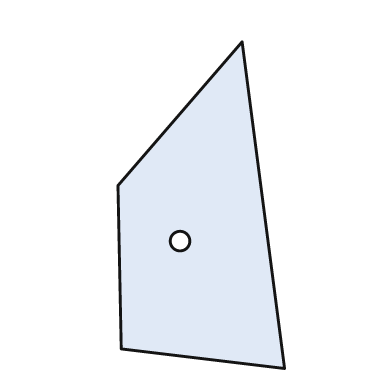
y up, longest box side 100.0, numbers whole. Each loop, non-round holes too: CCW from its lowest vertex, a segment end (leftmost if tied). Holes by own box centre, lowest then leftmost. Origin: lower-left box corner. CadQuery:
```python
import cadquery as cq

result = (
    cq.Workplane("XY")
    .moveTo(51.0, 0.0)
    .lineTo(38.0, 100.0)
    .lineTo(0.0, 56.0)
    .lineTo(1.0, 6.0)
    .close()
    .moveTo(19.0, 39.0)
    .circle(3.0)
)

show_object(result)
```